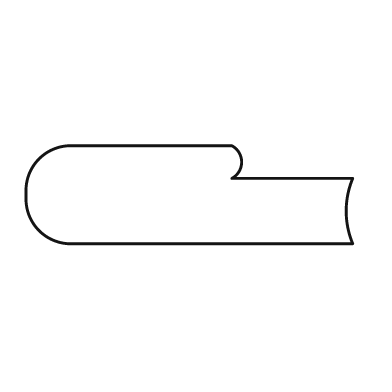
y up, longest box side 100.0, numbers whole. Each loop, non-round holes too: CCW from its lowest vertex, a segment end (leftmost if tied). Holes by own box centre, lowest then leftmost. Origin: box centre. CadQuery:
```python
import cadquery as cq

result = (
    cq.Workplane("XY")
    .moveTo(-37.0, -15.0)
    .lineTo(50.0, -15.0)
    .threePointArc((48.0, -5.0), (50.0, 5.0))
    .lineTo(13.0, 5.0)
    .threePointArc((16.0, 10.0), (13.0, 15.0))
    .lineTo(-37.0, 15.0)
    .threePointArc((-46.0, 11.0), (-50.0, 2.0))
    .lineTo(-50.0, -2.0)
    .threePointArc((-46.0, -11.0), (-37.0, -15.0))
    .close()
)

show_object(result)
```